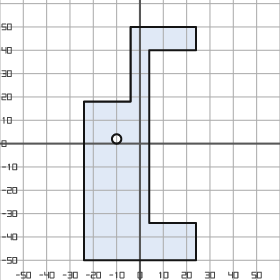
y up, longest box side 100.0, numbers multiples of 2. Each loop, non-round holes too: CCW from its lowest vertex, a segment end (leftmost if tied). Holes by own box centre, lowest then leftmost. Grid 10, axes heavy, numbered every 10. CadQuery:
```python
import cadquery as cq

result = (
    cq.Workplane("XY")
    .moveTo(-24.0, -50.0)
    .lineTo(24.0, -50.0)
    .lineTo(24.0, -34.0)
    .lineTo(4.0, -34.0)
    .lineTo(4.0, 40.0)
    .lineTo(24.0, 40.0)
    .lineTo(24.0, 50.0)
    .lineTo(-4.0, 50.0)
    .lineTo(-4.0, 18.0)
    .lineTo(-24.0, 18.0)
    .close()
    .moveTo(-10.0, 2.0)
    .circle(2.0)
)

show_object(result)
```